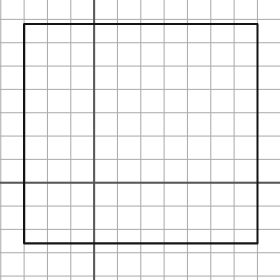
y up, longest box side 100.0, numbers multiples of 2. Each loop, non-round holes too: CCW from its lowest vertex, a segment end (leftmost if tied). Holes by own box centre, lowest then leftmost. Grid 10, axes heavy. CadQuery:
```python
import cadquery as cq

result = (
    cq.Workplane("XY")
    .moveTo(-30.0, -26.0)
    .lineTo(70.0, -26.0)
    .lineTo(70.0, 68.0)
    .lineTo(-30.0, 68.0)
    .close()
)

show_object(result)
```